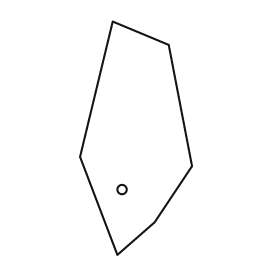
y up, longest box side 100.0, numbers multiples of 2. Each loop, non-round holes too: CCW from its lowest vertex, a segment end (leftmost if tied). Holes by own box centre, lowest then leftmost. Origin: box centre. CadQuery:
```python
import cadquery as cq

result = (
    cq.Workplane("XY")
    .moveTo(-8.0, -50.0)
    .lineTo(8.0, -36.0)
    .lineTo(24.0, -12.0)
    .lineTo(14.0, 40.0)
    .lineTo(-10.0, 50.0)
    .lineTo(-24.0, -8.0)
    .close()
    .moveTo(-6.0, -22.0)
    .circle(2.0)
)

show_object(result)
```